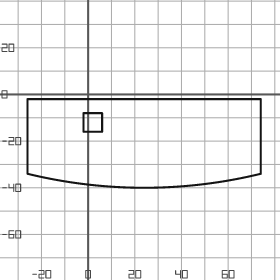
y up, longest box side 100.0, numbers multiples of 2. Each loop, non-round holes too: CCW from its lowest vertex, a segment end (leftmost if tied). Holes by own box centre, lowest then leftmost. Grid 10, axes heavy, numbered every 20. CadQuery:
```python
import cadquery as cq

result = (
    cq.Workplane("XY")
    .moveTo(-26.0, -34.0)
    .threePointArc((24.0, -40.0), (74.0, -34.0))
    .lineTo(74.0, -2.0)
    .lineTo(-26.0, -2.0)
    .close()
    .moveTo(-2.0, -16.0)
    .lineTo(6.0, -16.0)
    .lineTo(6.0, -8.0)
    .lineTo(-2.0, -8.0)
    .close()
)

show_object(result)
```